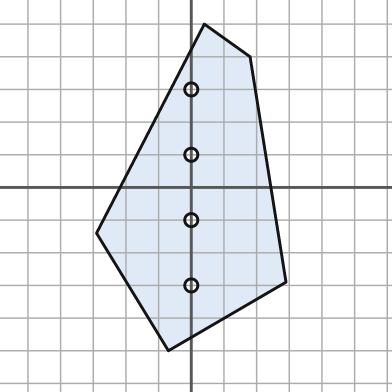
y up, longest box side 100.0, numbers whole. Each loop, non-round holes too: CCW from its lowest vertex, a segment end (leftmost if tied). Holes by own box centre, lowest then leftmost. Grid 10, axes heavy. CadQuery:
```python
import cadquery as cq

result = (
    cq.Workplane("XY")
    .moveTo(-7.0, -50.0)
    .lineTo(29.0, -29.0)
    .lineTo(18.0, 40.0)
    .lineTo(4.0, 50.0)
    .lineTo(-29.0, -14.0)
    .close()
    .moveTo(0.0, -30.0)
    .circle(2.0)
    .moveTo(0.0, -10.0)
    .circle(2.0)
    .moveTo(0.0, 10.0)
    .circle(2.0)
    .moveTo(0.0, 30.0)
    .circle(2.0)
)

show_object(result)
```